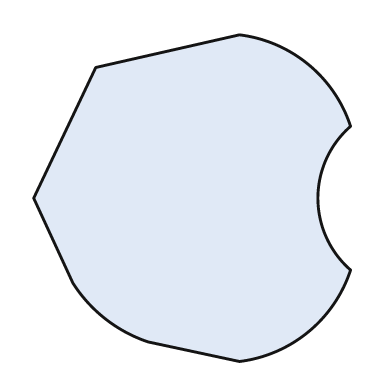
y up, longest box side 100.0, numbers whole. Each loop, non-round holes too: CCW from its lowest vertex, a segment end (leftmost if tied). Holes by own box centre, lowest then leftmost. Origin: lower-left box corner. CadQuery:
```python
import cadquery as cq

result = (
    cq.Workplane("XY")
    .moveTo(63.0, 0.0)
    .threePointArc((84.0, 9.0), (97.0, 28.0))
    .threePointArc((87.0, 50.0), (97.0, 72.0))
    .threePointArc((84.0, 91.0), (63.0, 100.0))
    .lineTo(19.0, 90.0)
    .lineTo(0.0, 50.0)
    .lineTo(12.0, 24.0)
    .threePointArc((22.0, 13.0), (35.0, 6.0))
    .close()
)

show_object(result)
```